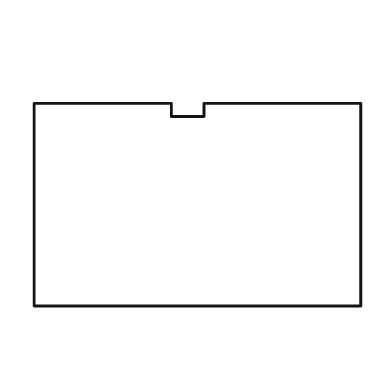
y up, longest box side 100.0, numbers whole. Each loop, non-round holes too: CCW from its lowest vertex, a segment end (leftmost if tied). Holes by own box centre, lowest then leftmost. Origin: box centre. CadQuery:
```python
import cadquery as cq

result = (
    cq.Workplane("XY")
    .moveTo(-50.0, -31.0)
    .lineTo(50.0, -31.0)
    .lineTo(50.0, 31.0)
    .lineTo(2.0, 31.0)
    .lineTo(2.0, 27.0)
    .lineTo(-8.0, 27.0)
    .lineTo(-8.0, 31.0)
    .lineTo(-50.0, 31.0)
    .close()
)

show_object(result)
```